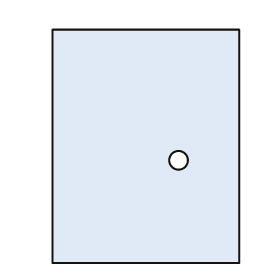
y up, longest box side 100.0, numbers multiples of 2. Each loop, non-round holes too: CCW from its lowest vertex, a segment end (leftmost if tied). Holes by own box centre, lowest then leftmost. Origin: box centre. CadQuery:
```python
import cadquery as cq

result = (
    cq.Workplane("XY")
    .moveTo(-40.0, -50.0)
    .lineTo(40.0, -50.0)
    .lineTo(40.0, 50.0)
    .lineTo(-40.0, 50.0)
    .close()
    .moveTo(14.0, -6.0)
    .circle(4.0)
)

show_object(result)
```